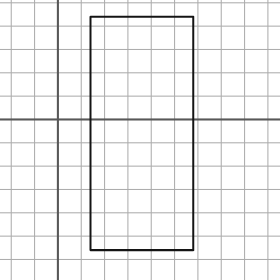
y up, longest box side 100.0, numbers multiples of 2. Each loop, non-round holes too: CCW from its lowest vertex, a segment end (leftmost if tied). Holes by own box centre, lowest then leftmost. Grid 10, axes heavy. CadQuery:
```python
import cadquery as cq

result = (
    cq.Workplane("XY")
    .moveTo(14.0, -56.0)
    .lineTo(58.0, -56.0)
    .lineTo(58.0, 44.0)
    .lineTo(14.0, 44.0)
    .close()
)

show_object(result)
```